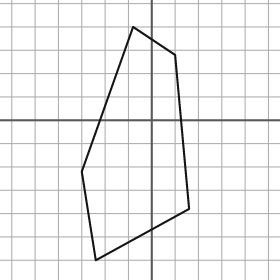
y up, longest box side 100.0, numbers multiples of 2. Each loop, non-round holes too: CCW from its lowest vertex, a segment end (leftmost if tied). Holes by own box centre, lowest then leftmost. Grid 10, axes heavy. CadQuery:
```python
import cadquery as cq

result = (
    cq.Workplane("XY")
    .moveTo(-24.0, -60.0)
    .lineTo(16.0, -38.0)
    .lineTo(10.0, 28.0)
    .lineTo(-8.0, 40.0)
    .lineTo(-30.0, -22.0)
    .close()
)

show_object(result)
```